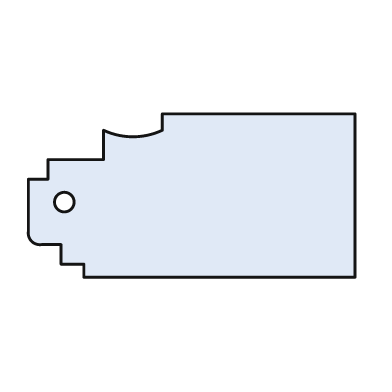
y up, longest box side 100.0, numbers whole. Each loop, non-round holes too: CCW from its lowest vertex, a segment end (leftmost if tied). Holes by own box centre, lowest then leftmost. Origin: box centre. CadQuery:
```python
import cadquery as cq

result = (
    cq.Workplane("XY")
    .moveTo(-33.0, -25.0)
    .lineTo(50.0, -25.0)
    .lineTo(50.0, 25.0)
    .lineTo(-9.0, 25.0)
    .lineTo(-9.0, 20.0)
    .threePointArc((-18.0, 18.0), (-27.0, 20.0))
    .lineTo(-27.0, 11.0)
    .lineTo(-44.0, 11.0)
    .lineTo(-44.0, 5.0)
    .lineTo(-50.0, 5.0)
    .lineTo(-50.0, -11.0)
    .threePointArc((-49.0, -14.0), (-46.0, -15.0))
    .lineTo(-40.0, -15.0)
    .lineTo(-40.0, -21.0)
    .lineTo(-33.0, -21.0)
    .close()
    .moveTo(-39.0, -2.0)
    .circle(3.0)
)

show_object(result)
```